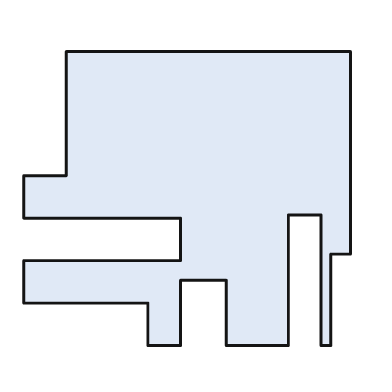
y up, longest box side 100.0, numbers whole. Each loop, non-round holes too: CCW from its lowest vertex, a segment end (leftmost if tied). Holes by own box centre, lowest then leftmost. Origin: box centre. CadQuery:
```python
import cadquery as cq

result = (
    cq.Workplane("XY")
    .moveTo(-12.0, -45.0)
    .lineTo(-2.0, -45.0)
    .lineTo(-2.0, -25.0)
    .lineTo(12.0, -25.0)
    .lineTo(12.0, -45.0)
    .lineTo(31.0, -45.0)
    .lineTo(31.0, -5.0)
    .lineTo(41.0, -5.0)
    .lineTo(41.0, -45.0)
    .lineTo(44.0, -45.0)
    .lineTo(44.0, -17.0)
    .lineTo(50.0, -17.0)
    .lineTo(50.0, 45.0)
    .lineTo(-37.0, 45.0)
    .lineTo(-37.0, 7.0)
    .lineTo(-50.0, 7.0)
    .lineTo(-50.0, -6.0)
    .lineTo(-2.0, -6.0)
    .lineTo(-2.0, -19.0)
    .lineTo(-50.0, -19.0)
    .lineTo(-50.0, -32.0)
    .lineTo(-12.0, -32.0)
    .close()
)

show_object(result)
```